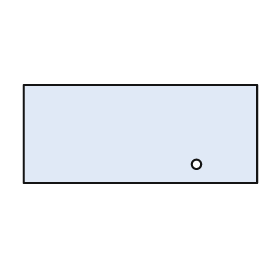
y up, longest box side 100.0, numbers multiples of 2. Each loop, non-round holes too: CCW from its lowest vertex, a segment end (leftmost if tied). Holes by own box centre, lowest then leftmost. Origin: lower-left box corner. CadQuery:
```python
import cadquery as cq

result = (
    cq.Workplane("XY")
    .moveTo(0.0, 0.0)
    .lineTo(100.0, 0.0)
    .lineTo(100.0, 42.0)
    .lineTo(0.0, 42.0)
    .close()
    .moveTo(74.0, 8.0)
    .circle(2.0)
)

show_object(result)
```